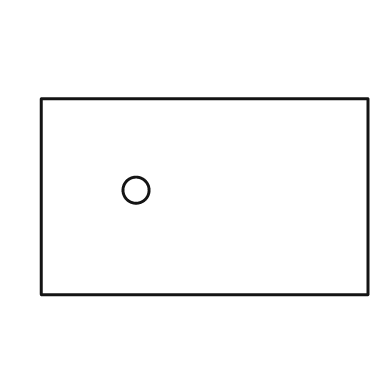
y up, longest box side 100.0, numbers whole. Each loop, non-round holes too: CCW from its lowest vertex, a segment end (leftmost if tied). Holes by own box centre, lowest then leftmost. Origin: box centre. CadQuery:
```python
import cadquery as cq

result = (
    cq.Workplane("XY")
    .moveTo(-50.0, -30.0)
    .lineTo(50.0, -30.0)
    .lineTo(50.0, 30.0)
    .lineTo(-50.0, 30.0)
    .close()
    .moveTo(-21.0, 2.0)
    .circle(4.0)
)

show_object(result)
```